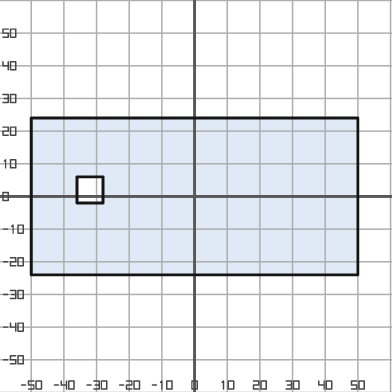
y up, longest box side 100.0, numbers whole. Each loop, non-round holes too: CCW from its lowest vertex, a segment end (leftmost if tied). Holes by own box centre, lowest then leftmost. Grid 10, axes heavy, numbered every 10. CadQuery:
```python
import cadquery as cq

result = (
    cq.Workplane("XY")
    .moveTo(-50.0, -24.0)
    .lineTo(50.0, -24.0)
    .lineTo(50.0, 24.0)
    .lineTo(-50.0, 24.0)
    .close()
    .moveTo(-36.0, -2.0)
    .lineTo(-28.0, -2.0)
    .lineTo(-28.0, 6.0)
    .lineTo(-36.0, 6.0)
    .close()
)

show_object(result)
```